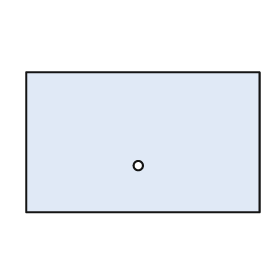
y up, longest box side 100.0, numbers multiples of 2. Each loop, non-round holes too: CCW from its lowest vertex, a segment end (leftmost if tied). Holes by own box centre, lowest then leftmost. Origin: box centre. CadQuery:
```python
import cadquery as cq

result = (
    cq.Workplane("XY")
    .moveTo(-50.0, -30.0)
    .lineTo(50.0, -30.0)
    .lineTo(50.0, 30.0)
    .lineTo(-50.0, 30.0)
    .close()
    .moveTo(-2.0, -10.0)
    .circle(2.0)
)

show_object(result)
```